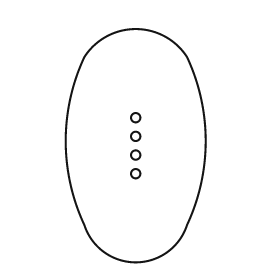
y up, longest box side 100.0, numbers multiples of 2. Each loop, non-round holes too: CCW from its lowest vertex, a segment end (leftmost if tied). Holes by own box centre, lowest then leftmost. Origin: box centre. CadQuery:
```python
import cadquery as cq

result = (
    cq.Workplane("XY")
    .moveTo(-22.0, -34.0)
    .threePointArc((0.0, -50.0), (22.0, -34.0))
    .threePointArc((30.0, 2.0), (22.0, 38.0))
    .threePointArc((0.0, 50.0), (-22.0, 38.0))
    .threePointArc((-30.0, 2.0), (-22.0, -34.0))
    .close()
    .moveTo(0.0, -12.0)
    .circle(2.0)
    .moveTo(0.0, -4.0)
    .circle(2.0)
    .moveTo(0.0, 4.0)
    .circle(2.0)
    .moveTo(0.0, 12.0)
    .circle(2.0)
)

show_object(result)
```